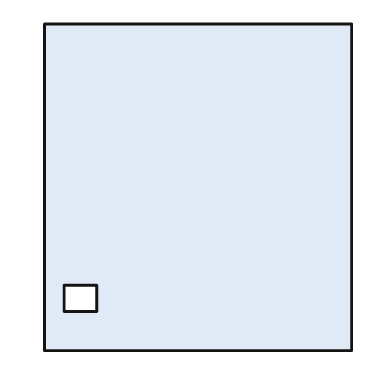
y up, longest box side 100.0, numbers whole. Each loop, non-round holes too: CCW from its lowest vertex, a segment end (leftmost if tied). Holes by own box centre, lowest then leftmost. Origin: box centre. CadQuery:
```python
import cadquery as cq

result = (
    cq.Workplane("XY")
    .moveTo(-47.0, -50.0)
    .lineTo(47.0, -50.0)
    .lineTo(47.0, 50.0)
    .lineTo(-47.0, 50.0)
    .close()
    .moveTo(-41.0, -38.0)
    .lineTo(-31.0, -38.0)
    .lineTo(-31.0, -30.0)
    .lineTo(-41.0, -30.0)
    .close()
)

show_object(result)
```